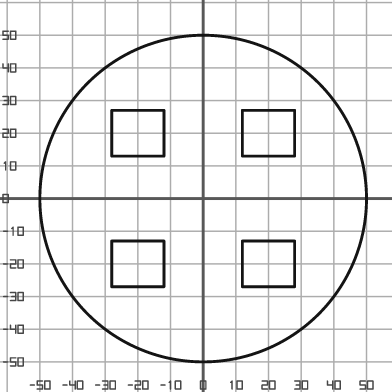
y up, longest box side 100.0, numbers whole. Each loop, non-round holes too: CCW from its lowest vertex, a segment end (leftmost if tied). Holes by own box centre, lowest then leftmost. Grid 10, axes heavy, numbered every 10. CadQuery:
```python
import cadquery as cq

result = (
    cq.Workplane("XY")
    .moveTo(0.0, 0.0)
    .circle(50.0)
    .moveTo(-28.0, -27.0)
    .lineTo(-12.0, -27.0)
    .lineTo(-12.0, -13.0)
    .lineTo(-28.0, -13.0)
    .close()
    .moveTo(12.0, -27.0)
    .lineTo(28.0, -27.0)
    .lineTo(28.0, -13.0)
    .lineTo(12.0, -13.0)
    .close()
    .moveTo(-28.0, 13.0)
    .lineTo(-12.0, 13.0)
    .lineTo(-12.0, 27.0)
    .lineTo(-28.0, 27.0)
    .close()
    .moveTo(12.0, 13.0)
    .lineTo(28.0, 13.0)
    .lineTo(28.0, 27.0)
    .lineTo(12.0, 27.0)
    .close()
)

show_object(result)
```